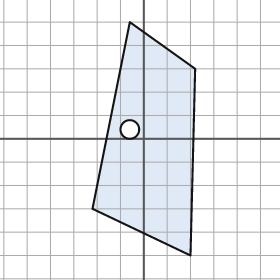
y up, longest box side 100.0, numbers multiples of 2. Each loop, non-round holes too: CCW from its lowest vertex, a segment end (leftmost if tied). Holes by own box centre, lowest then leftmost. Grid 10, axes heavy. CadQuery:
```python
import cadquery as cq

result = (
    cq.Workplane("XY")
    .moveTo(20.0, -50.0)
    .lineTo(22.0, 30.0)
    .lineTo(-6.0, 50.0)
    .lineTo(-22.0, -30.0)
    .close()
    .moveTo(-6.0, 4.0)
    .circle(4.0)
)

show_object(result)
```